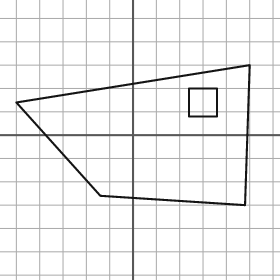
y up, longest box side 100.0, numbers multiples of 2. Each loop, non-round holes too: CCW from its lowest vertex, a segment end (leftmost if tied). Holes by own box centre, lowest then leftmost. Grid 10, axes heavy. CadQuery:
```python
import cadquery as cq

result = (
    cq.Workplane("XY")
    .moveTo(48.0, -30.0)
    .lineTo(50.0, 30.0)
    .lineTo(-50.0, 14.0)
    .lineTo(-14.0, -26.0)
    .close()
    .moveTo(24.0, 8.0)
    .lineTo(36.0, 8.0)
    .lineTo(36.0, 20.0)
    .lineTo(24.0, 20.0)
    .close()
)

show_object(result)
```